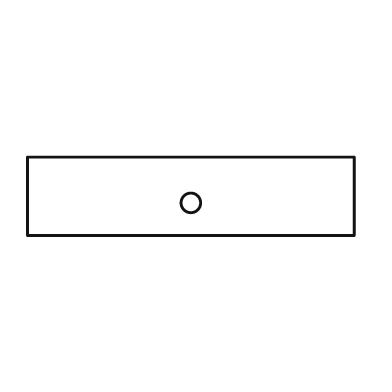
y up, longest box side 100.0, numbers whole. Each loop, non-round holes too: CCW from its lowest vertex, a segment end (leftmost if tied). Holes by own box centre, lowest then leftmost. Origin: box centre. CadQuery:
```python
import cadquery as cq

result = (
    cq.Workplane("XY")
    .moveTo(-50.0, -12.0)
    .lineTo(50.0, -12.0)
    .lineTo(50.0, 12.0)
    .lineTo(-50.0, 12.0)
    .close()
    .moveTo(0.0, -2.0)
    .circle(3.0)
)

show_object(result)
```